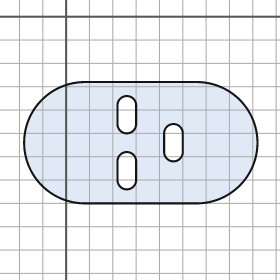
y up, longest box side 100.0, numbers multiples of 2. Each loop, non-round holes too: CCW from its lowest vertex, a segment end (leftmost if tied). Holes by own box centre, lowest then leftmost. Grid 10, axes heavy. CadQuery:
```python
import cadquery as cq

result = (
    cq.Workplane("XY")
    .moveTo(8.0, -80.0)
    .lineTo(56.0, -80.0)
    .threePointArc((82.0, -54.0), (56.0, -28.0))
    .lineTo(8.0, -28.0)
    .threePointArc((-18.0, -54.0), (8.0, -80.0))
    .close()
    .moveTo(22.0, -70.0)
    .threePointArc((26.0, -74.0), (30.0, -70.0))
    .lineTo(30.0, -62.0)
    .threePointArc((26.0, -58.0), (22.0, -62.0))
    .close()
    .moveTo(42.0, -58.0)
    .threePointArc((46.0, -62.0), (50.0, -58.0))
    .lineTo(50.0, -50.0)
    .threePointArc((46.0, -46.0), (42.0, -50.0))
    .close()
    .moveTo(22.0, -46.0)
    .threePointArc((26.0, -50.0), (30.0, -46.0))
    .lineTo(30.0, -38.0)
    .threePointArc((26.0, -34.0), (22.0, -38.0))
    .close()
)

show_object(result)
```